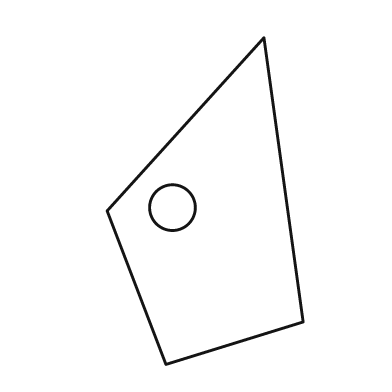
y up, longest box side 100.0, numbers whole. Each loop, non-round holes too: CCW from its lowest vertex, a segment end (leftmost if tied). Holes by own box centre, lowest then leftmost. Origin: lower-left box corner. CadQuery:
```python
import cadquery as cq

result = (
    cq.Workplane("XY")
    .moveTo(18.0, 0.0)
    .lineTo(60.0, 13.0)
    .lineTo(48.0, 100.0)
    .lineTo(0.0, 47.0)
    .close()
    .moveTo(20.0, 48.0)
    .circle(7.0)
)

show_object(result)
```